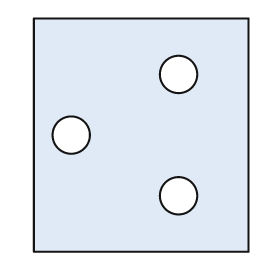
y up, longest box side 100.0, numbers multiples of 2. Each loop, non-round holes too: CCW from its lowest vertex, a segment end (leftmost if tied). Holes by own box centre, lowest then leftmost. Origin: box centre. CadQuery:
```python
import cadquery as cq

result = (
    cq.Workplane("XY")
    .moveTo(-46.0, -50.0)
    .lineTo(46.0, -50.0)
    .lineTo(46.0, 50.0)
    .lineTo(-46.0, 50.0)
    .close()
    .moveTo(16.0, -26.0)
    .circle(8.0)
    .moveTo(-30.0, 0.0)
    .circle(8.0)
    .moveTo(16.0, 26.0)
    .circle(8.0)
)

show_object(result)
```